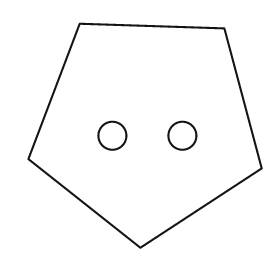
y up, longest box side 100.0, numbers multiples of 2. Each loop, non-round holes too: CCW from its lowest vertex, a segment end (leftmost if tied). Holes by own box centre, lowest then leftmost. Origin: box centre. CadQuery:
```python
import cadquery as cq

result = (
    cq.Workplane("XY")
    .moveTo(-2.0, -48.0)
    .lineTo(50.0, -14.0)
    .lineTo(34.0, 46.0)
    .lineTo(-28.0, 48.0)
    .lineTo(-50.0, -10.0)
    .close()
    .moveTo(-14.0, 0.0)
    .circle(6.0)
    .moveTo(16.0, 0.0)
    .circle(6.0)
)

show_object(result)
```